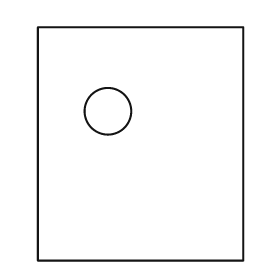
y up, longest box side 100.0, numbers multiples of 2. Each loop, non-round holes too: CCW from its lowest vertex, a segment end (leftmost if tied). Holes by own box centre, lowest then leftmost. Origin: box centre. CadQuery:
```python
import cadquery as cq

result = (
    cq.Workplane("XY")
    .moveTo(-44.0, -50.0)
    .lineTo(44.0, -50.0)
    .lineTo(44.0, 50.0)
    .lineTo(-44.0, 50.0)
    .close()
    .moveTo(-14.0, 14.0)
    .circle(10.0)
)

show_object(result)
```